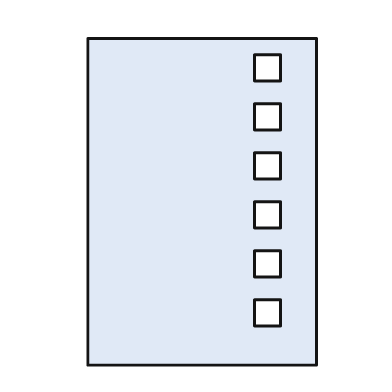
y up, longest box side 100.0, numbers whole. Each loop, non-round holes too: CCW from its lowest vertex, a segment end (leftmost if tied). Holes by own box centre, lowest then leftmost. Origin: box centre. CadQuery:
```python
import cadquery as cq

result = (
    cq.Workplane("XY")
    .moveTo(-35.0, -50.0)
    .lineTo(35.0, -50.0)
    .lineTo(35.0, 50.0)
    .lineTo(-35.0, 50.0)
    .close()
    .moveTo(16.0, -38.0)
    .lineTo(24.0, -38.0)
    .lineTo(24.0, -30.0)
    .lineTo(16.0, -30.0)
    .close()
    .moveTo(16.0, -23.0)
    .lineTo(24.0, -23.0)
    .lineTo(24.0, -15.0)
    .lineTo(16.0, -15.0)
    .close()
    .moveTo(16.0, -8.0)
    .lineTo(24.0, -8.0)
    .lineTo(24.0, 0.0)
    .lineTo(16.0, 0.0)
    .close()
    .moveTo(16.0, 7.0)
    .lineTo(24.0, 7.0)
    .lineTo(24.0, 15.0)
    .lineTo(16.0, 15.0)
    .close()
    .moveTo(16.0, 22.0)
    .lineTo(24.0, 22.0)
    .lineTo(24.0, 30.0)
    .lineTo(16.0, 30.0)
    .close()
    .moveTo(16.0, 37.0)
    .lineTo(24.0, 37.0)
    .lineTo(24.0, 45.0)
    .lineTo(16.0, 45.0)
    .close()
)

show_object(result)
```